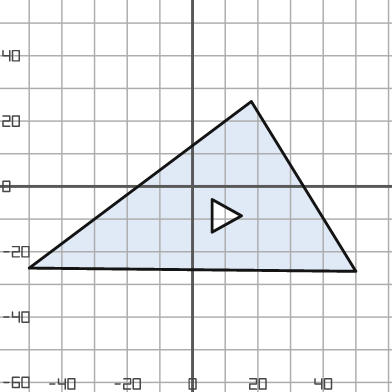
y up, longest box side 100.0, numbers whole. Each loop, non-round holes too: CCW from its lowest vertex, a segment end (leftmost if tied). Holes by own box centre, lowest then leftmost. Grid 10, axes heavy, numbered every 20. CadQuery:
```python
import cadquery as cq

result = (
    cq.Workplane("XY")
    .moveTo(50.0, -26.0)
    .lineTo(18.0, 26.0)
    .lineTo(-50.0, -25.0)
    .close()
    .moveTo(6.0, -14.0)
    .lineTo(15.0, -9.0)
    .lineTo(6.0, -4.0)
    .close()
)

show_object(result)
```